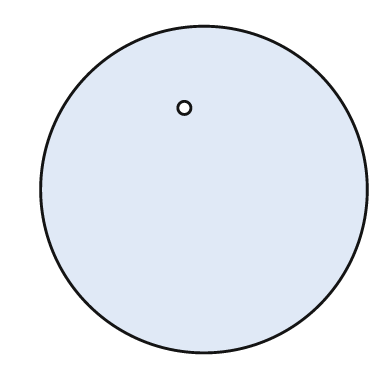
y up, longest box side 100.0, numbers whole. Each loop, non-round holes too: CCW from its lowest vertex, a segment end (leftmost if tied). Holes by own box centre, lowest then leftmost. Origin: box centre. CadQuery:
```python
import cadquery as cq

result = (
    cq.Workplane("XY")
    .moveTo(0.0, 0.0)
    .circle(50.0)
    .moveTo(-6.0, 25.0)
    .circle(2.0)
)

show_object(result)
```